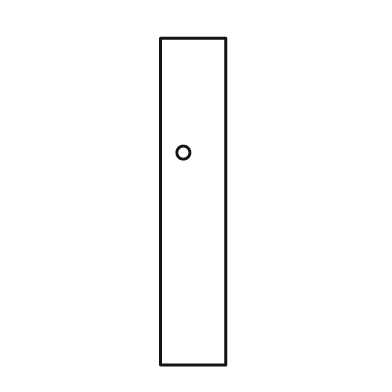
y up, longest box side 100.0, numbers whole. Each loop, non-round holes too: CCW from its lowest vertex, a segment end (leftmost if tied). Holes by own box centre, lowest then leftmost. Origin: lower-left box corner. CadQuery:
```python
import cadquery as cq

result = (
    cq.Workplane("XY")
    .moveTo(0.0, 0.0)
    .lineTo(20.0, 0.0)
    .lineTo(20.0, 100.0)
    .lineTo(0.0, 100.0)
    .close()
    .moveTo(7.0, 65.0)
    .circle(2.0)
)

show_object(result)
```